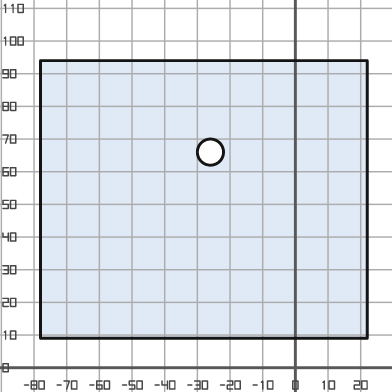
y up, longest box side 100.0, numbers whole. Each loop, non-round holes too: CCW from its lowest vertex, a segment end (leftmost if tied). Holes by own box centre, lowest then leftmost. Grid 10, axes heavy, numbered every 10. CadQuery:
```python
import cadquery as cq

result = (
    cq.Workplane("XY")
    .moveTo(-78.0, 9.0)
    .lineTo(22.0, 9.0)
    .lineTo(22.0, 94.0)
    .lineTo(-78.0, 94.0)
    .close()
    .moveTo(-26.0, 66.0)
    .circle(4.0)
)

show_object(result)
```